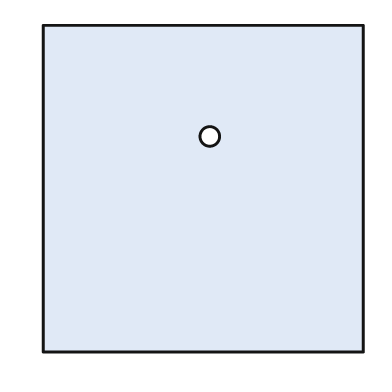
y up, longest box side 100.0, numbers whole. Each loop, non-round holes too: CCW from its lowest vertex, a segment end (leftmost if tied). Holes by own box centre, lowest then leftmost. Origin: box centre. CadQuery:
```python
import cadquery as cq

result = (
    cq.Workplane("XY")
    .moveTo(-49.0, -50.0)
    .lineTo(49.0, -50.0)
    .lineTo(49.0, 50.0)
    .lineTo(-49.0, 50.0)
    .close()
    .moveTo(2.0, 16.0)
    .circle(3.0)
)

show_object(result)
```